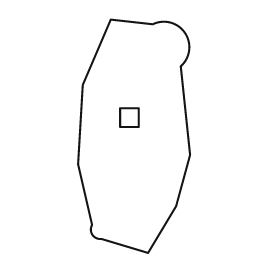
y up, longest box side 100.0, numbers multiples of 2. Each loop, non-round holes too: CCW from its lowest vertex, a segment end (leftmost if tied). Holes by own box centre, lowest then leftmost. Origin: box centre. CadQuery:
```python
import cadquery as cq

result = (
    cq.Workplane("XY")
    .moveTo(6.0, -50.0)
    .lineTo(18.0, -30.0)
    .lineTo(24.0, -8.0)
    .lineTo(20.0, 30.0)
    .threePointArc((22.0, 44.0), (8.0, 48.0))
    .lineTo(-10.0, 50.0)
    .lineTo(-22.0, 22.0)
    .lineTo(-24.0, -12.0)
    .lineTo(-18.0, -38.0)
    .threePointArc((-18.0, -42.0), (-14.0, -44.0))
    .close()
    .moveTo(-6.0, 4.0)
    .lineTo(2.0, 4.0)
    .lineTo(2.0, 12.0)
    .lineTo(-6.0, 12.0)
    .close()
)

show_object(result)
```